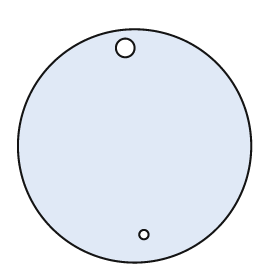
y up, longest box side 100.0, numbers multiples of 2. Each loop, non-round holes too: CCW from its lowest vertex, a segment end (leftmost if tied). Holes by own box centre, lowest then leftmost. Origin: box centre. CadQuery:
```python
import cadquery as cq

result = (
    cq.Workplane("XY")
    .moveTo(0.0, 0.0)
    .circle(50.0)
    .moveTo(4.0, -38.0)
    .circle(2.0)
    .moveTo(-4.0, 42.0)
    .circle(4.0)
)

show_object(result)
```